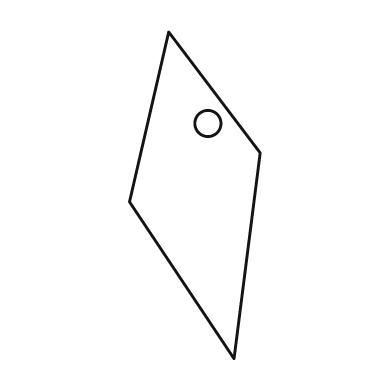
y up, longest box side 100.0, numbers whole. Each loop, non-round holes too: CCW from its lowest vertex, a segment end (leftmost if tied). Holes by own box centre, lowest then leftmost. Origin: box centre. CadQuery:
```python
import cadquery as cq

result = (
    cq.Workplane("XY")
    .moveTo(12.0, -50.0)
    .lineTo(20.0, 13.0)
    .lineTo(-8.0, 50.0)
    .lineTo(-20.0, -2.0)
    .close()
    .moveTo(4.0, 22.0)
    .circle(4.0)
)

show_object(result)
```